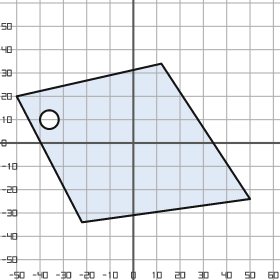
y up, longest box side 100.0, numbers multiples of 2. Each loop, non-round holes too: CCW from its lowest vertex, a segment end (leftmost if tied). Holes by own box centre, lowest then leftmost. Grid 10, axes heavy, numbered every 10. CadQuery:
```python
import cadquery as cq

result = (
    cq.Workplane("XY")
    .moveTo(-22.0, -34.0)
    .lineTo(50.0, -24.0)
    .lineTo(12.0, 34.0)
    .lineTo(-50.0, 20.0)
    .close()
    .moveTo(-36.0, 10.0)
    .circle(4.0)
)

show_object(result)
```